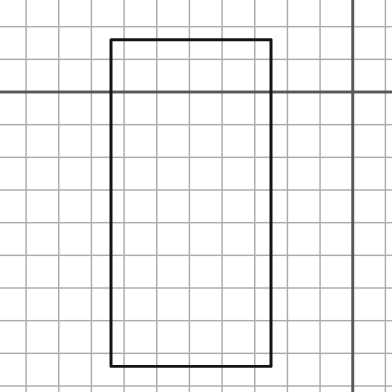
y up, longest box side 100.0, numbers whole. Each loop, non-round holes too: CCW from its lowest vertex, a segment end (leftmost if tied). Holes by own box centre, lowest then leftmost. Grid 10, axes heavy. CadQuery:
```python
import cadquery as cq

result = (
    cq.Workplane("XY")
    .moveTo(-74.0, -84.0)
    .lineTo(-25.0, -84.0)
    .lineTo(-25.0, 16.0)
    .lineTo(-74.0, 16.0)
    .close()
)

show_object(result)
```